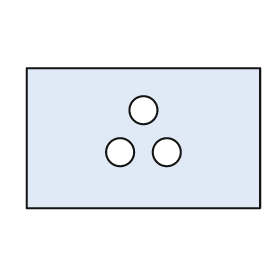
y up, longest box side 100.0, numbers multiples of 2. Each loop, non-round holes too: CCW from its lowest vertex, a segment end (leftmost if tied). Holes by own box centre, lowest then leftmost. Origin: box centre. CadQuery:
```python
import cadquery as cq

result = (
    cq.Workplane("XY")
    .moveTo(-50.0, -30.0)
    .lineTo(50.0, -30.0)
    .lineTo(50.0, 30.0)
    .lineTo(-50.0, 30.0)
    .close()
    .moveTo(-10.0, -6.0)
    .circle(6.0)
    .moveTo(10.0, -6.0)
    .circle(6.0)
    .moveTo(0.0, 12.0)
    .circle(6.0)
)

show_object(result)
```